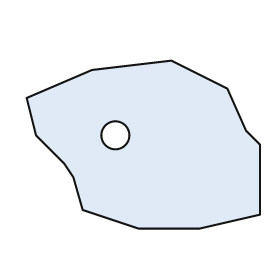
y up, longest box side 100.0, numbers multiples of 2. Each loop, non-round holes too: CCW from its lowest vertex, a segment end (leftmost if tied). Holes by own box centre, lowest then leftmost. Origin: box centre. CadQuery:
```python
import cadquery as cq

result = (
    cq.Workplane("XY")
    .moveTo(-2.0, -36.0)
    .lineTo(24.0, -36.0)
    .lineTo(50.0, -30.0)
    .lineTo(50.0, 0.0)
    .lineTo(44.0, 6.0)
    .lineTo(36.0, 24.0)
    .lineTo(12.0, 36.0)
    .lineTo(-22.0, 32.0)
    .lineTo(-50.0, 20.0)
    .lineTo(-46.0, 4.0)
    .lineTo(-34.0, -8.0)
    .lineTo(-30.0, -14.0)
    .lineTo(-26.0, -28.0)
    .close()
    .moveTo(-12.0, 4.0)
    .circle(6.0)
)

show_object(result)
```